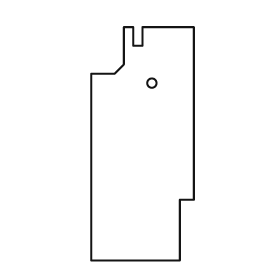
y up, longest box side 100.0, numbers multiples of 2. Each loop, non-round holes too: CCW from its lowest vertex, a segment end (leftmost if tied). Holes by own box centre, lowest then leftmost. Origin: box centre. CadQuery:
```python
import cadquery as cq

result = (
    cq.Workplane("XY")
    .moveTo(-22.0, -50.0)
    .lineTo(16.0, -50.0)
    .lineTo(16.0, -24.0)
    .lineTo(22.0, -24.0)
    .lineTo(22.0, 50.0)
    .lineTo(0.0, 50.0)
    .lineTo(0.0, 42.0)
    .lineTo(-4.0, 42.0)
    .lineTo(-4.0, 50.0)
    .lineTo(-8.0, 50.0)
    .lineTo(-8.0, 34.0)
    .lineTo(-12.0, 30.0)
    .lineTo(-22.0, 30.0)
    .close()
    .moveTo(4.0, 26.0)
    .circle(2.0)
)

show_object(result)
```